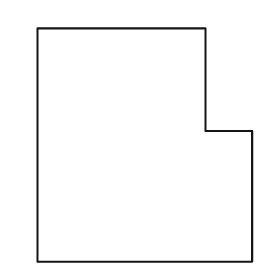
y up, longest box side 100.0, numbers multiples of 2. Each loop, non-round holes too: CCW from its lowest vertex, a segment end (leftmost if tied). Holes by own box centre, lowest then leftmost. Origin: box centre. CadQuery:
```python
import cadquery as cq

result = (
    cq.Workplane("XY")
    .moveTo(-46.0, -50.0)
    .lineTo(46.0, -50.0)
    .lineTo(46.0, 6.0)
    .lineTo(26.0, 6.0)
    .lineTo(26.0, 50.0)
    .lineTo(-46.0, 50.0)
    .close()
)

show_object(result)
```